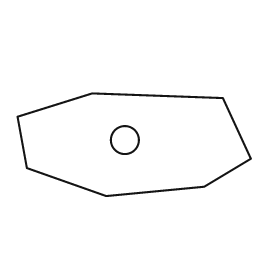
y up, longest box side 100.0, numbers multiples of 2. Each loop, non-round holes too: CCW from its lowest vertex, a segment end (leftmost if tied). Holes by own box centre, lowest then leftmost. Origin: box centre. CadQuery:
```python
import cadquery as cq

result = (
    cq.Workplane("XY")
    .moveTo(-12.0, -22.0)
    .lineTo(30.0, -18.0)
    .lineTo(50.0, -6.0)
    .lineTo(38.0, 20.0)
    .lineTo(-18.0, 22.0)
    .lineTo(-50.0, 12.0)
    .lineTo(-46.0, -10.0)
    .close()
    .moveTo(-4.0, 2.0)
    .circle(6.0)
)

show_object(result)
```